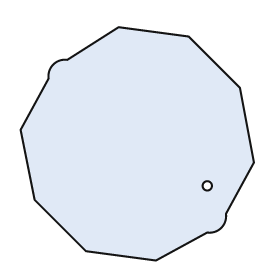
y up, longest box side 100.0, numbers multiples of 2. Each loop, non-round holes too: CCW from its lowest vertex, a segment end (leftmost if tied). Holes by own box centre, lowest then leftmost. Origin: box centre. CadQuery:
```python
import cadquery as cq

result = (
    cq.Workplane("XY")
    .moveTo(8.0, -50.0)
    .lineTo(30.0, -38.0)
    .threePointArc((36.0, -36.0), (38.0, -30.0))
    .lineTo(50.0, -8.0)
    .lineTo(44.0, 24.0)
    .lineTo(22.0, 46.0)
    .lineTo(-8.0, 50.0)
    .lineTo(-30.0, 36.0)
    .threePointArc((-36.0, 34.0), (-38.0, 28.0))
    .lineTo(-50.0, 6.0)
    .lineTo(-44.0, -24.0)
    .lineTo(-22.0, -46.0)
    .close()
    .moveTo(30.0, -18.0)
    .circle(2.0)
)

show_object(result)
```